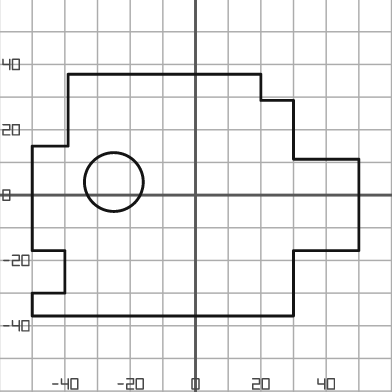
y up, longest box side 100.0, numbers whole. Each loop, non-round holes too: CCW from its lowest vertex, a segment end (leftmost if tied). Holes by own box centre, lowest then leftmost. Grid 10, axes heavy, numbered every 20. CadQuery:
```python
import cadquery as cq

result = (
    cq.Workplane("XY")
    .moveTo(-50.0, -37.0)
    .lineTo(30.0, -37.0)
    .lineTo(30.0, -17.0)
    .lineTo(50.0, -17.0)
    .lineTo(50.0, 11.0)
    .lineTo(30.0, 11.0)
    .lineTo(30.0, 29.0)
    .lineTo(20.0, 29.0)
    .lineTo(20.0, 37.0)
    .lineTo(-39.0, 37.0)
    .lineTo(-39.0, 15.0)
    .lineTo(-50.0, 15.0)
    .lineTo(-50.0, -17.0)
    .lineTo(-40.0, -17.0)
    .lineTo(-40.0, -30.0)
    .lineTo(-50.0, -30.0)
    .close()
    .moveTo(-25.0, 4.0)
    .circle(9.0)
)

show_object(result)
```